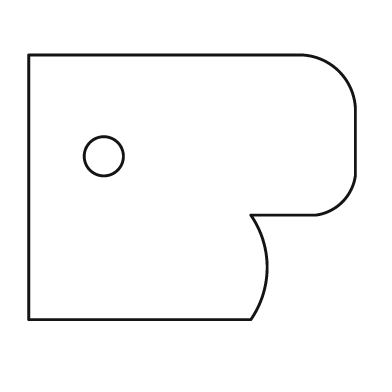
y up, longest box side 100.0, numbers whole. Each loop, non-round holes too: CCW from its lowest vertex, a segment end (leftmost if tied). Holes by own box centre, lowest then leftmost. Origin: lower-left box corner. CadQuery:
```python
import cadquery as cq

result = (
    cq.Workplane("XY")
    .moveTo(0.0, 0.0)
    .lineTo(68.0, 0.0)
    .threePointArc((73.0, 16.0), (68.0, 32.0))
    .lineTo(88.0, 32.0)
    .threePointArc((96.0, 36.0), (100.0, 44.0))
    .lineTo(100.0, 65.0)
    .threePointArc((95.0, 76.0), (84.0, 81.0))
    .lineTo(0.0, 81.0)
    .close()
    .moveTo(23.0, 50.0)
    .circle(6.0)
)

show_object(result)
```